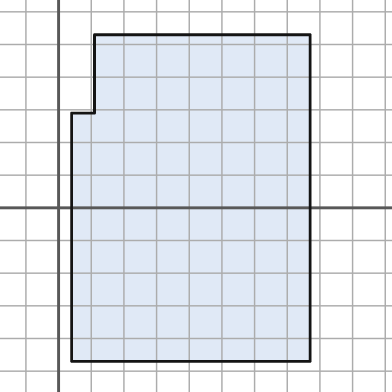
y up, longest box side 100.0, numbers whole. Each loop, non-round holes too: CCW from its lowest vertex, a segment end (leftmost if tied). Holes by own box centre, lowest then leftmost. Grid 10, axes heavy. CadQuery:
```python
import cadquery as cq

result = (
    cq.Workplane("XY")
    .moveTo(4.0, -47.0)
    .lineTo(77.0, -47.0)
    .lineTo(77.0, 53.0)
    .lineTo(11.0, 53.0)
    .lineTo(11.0, 29.0)
    .lineTo(4.0, 29.0)
    .close()
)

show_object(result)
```